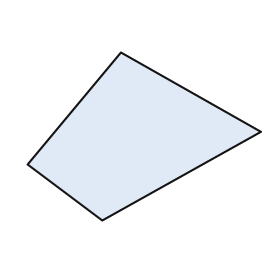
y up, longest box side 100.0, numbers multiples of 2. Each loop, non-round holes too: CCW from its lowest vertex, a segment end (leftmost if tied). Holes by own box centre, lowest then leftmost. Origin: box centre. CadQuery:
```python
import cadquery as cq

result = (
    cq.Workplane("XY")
    .moveTo(-18.0, -36.0)
    .lineTo(50.0, 2.0)
    .lineTo(-10.0, 36.0)
    .lineTo(-50.0, -12.0)
    .close()
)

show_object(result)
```